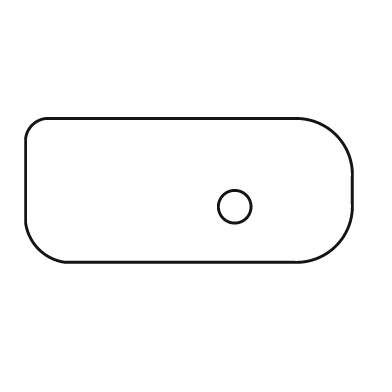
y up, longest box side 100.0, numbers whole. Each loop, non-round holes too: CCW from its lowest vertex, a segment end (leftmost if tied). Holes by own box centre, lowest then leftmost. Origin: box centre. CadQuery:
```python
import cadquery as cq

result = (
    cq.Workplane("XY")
    .moveTo(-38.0, -22.0)
    .lineTo(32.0, -22.0)
    .threePointArc((45.0, -17.0), (50.0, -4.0))
    .lineTo(50.0, 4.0)
    .threePointArc((45.0, 17.0), (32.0, 22.0))
    .lineTo(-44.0, 22.0)
    .threePointArc((-48.0, 20.0), (-50.0, 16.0))
    .lineTo(-50.0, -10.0)
    .threePointArc((-46.0, -18.0), (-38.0, -22.0))
    .close()
    .moveTo(14.0, -5.0)
    .circle(5.0)
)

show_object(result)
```